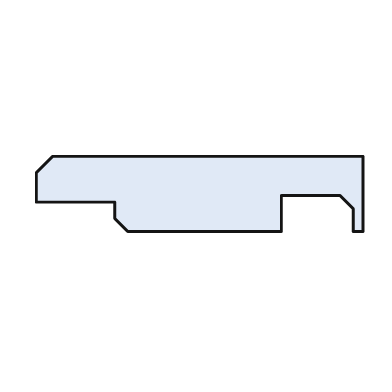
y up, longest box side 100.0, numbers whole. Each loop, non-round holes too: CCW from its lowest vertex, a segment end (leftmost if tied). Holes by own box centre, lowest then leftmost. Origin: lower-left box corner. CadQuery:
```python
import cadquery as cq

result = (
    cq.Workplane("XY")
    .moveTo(28.0, 0.0)
    .lineTo(75.0, 0.0)
    .lineTo(75.0, 11.0)
    .lineTo(93.0, 11.0)
    .lineTo(97.0, 7.0)
    .lineTo(97.0, 0.0)
    .lineTo(100.0, 0.0)
    .lineTo(100.0, 23.0)
    .lineTo(5.0, 23.0)
    .lineTo(0.0, 18.0)
    .lineTo(0.0, 9.0)
    .lineTo(24.0, 9.0)
    .lineTo(24.0, 4.0)
    .close()
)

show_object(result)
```